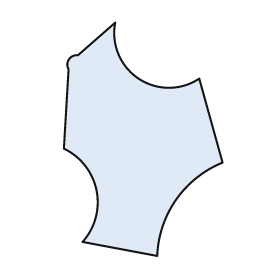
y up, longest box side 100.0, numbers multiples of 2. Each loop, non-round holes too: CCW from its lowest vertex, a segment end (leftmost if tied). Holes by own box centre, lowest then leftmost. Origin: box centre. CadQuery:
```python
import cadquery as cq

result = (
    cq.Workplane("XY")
    .moveTo(6.0, -50.0)
    .threePointArc((14.0, -26.0), (34.0, -10.0))
    .lineTo(24.0, 26.0)
    .threePointArc((-2.0, 26.0), (-12.0, 50.0))
    .lineTo(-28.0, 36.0)
    .threePointArc((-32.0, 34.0), (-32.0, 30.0))
    .lineTo(-34.0, -4.0)
    .threePointArc((-20.0, -22.0), (-26.0, -44.0))
    .close()
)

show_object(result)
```